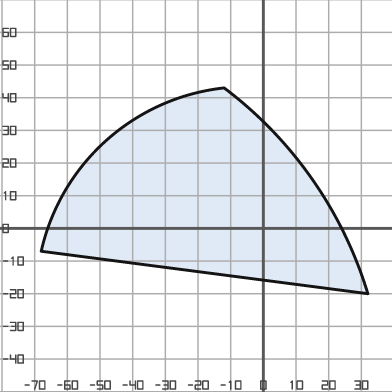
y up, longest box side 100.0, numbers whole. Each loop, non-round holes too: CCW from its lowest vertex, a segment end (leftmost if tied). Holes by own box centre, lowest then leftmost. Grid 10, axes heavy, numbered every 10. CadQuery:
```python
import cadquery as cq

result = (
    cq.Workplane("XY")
    .moveTo(32.0, -20.0)
    .threePointArc((15.0, 15.0), (-12.0, 43.0))
    .threePointArc((-48.0, 27.0), (-68.0, -7.0))
    .close()
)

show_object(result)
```